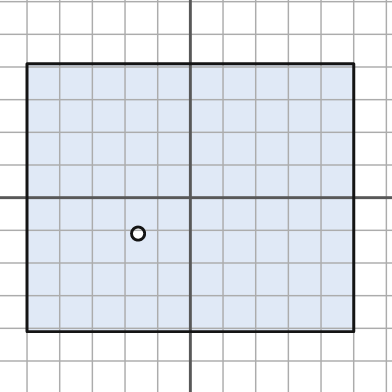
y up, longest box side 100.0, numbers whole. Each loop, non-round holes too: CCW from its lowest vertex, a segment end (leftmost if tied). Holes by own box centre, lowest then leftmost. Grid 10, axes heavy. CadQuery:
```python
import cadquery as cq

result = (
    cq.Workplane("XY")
    .moveTo(-50.0, -41.0)
    .lineTo(50.0, -41.0)
    .lineTo(50.0, 41.0)
    .lineTo(-50.0, 41.0)
    .close()
    .moveTo(-16.0, -11.0)
    .circle(2.0)
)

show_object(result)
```